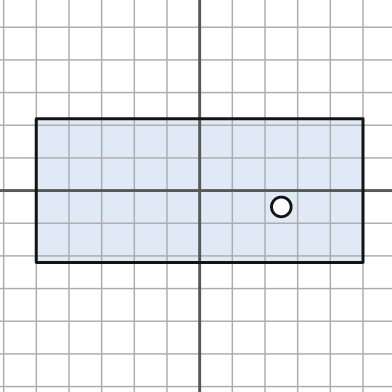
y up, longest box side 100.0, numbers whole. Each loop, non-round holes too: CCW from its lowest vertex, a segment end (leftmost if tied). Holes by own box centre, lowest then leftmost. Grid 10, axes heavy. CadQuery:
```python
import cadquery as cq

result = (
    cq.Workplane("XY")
    .moveTo(-50.0, -22.0)
    .lineTo(50.0, -22.0)
    .lineTo(50.0, 22.0)
    .lineTo(-50.0, 22.0)
    .close()
    .moveTo(25.0, -5.0)
    .circle(3.0)
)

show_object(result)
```